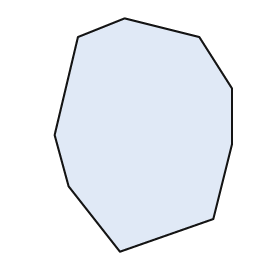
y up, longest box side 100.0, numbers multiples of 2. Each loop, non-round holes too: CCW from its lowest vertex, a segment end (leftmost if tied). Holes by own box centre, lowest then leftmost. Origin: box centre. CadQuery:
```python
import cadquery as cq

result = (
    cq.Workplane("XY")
    .moveTo(-10.0, -50.0)
    .lineTo(30.0, -36.0)
    .lineTo(38.0, -4.0)
    .lineTo(38.0, 20.0)
    .lineTo(24.0, 42.0)
    .lineTo(-8.0, 50.0)
    .lineTo(-28.0, 42.0)
    .lineTo(-38.0, 0.0)
    .lineTo(-32.0, -22.0)
    .close()
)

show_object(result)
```